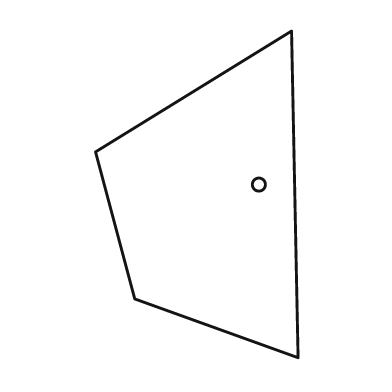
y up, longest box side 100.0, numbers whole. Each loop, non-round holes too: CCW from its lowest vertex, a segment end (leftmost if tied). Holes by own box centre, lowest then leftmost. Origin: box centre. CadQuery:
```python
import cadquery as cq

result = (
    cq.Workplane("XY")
    .moveTo(31.0, -50.0)
    .lineTo(29.0, 50.0)
    .lineTo(-31.0, 13.0)
    .lineTo(-19.0, -32.0)
    .close()
    .moveTo(19.0, 3.0)
    .circle(2.0)
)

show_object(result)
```